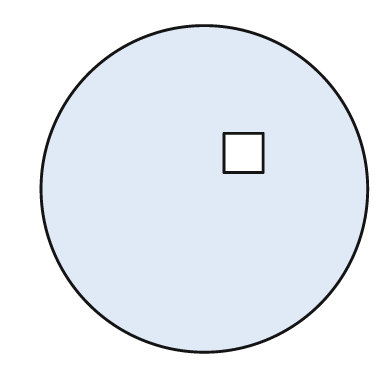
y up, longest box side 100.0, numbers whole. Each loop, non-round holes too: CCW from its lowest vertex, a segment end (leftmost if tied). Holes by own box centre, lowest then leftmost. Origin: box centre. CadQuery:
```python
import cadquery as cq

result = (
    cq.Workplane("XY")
    .moveTo(0.0, 0.0)
    .circle(50.0)
    .moveTo(6.0, 5.0)
    .lineTo(18.0, 5.0)
    .lineTo(18.0, 17.0)
    .lineTo(6.0, 17.0)
    .close()
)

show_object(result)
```